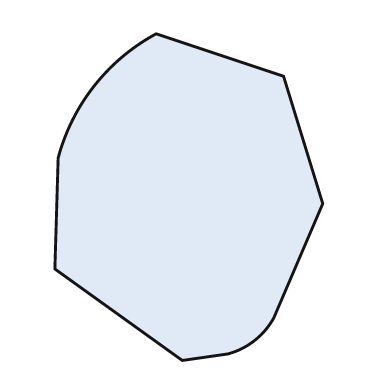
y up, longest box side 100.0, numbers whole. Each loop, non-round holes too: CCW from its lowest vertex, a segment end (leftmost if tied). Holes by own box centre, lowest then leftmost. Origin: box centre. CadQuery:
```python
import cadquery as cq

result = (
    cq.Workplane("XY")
    .moveTo(-2.0, -50.0)
    .lineTo(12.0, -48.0)
    .threePointArc((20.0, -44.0), (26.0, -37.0))
    .lineTo(41.0, -2.0)
    .lineTo(29.0, 37.0)
    .lineTo(-10.0, 50.0)
    .threePointArc((-29.0, 34.0), (-40.0, 12.0))
    .lineTo(-41.0, -22.0)
    .close()
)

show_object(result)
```